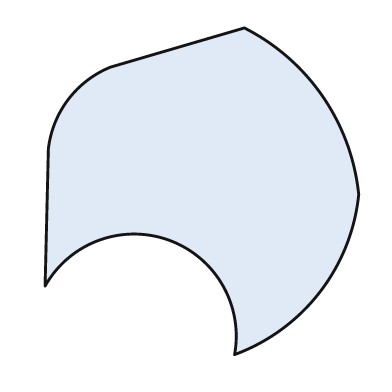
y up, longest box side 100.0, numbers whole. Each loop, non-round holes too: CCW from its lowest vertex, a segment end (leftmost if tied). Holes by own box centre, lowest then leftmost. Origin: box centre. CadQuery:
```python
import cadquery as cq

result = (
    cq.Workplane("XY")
    .moveTo(10.0, -50.0)
    .threePointArc((36.0, -31.0), (48.0, -1.0))
    .threePointArc((37.0, 29.0), (13.0, 50.0))
    .lineTo(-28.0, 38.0)
    .threePointArc((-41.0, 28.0), (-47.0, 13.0))
    .lineTo(-48.0, -29.0)
    .threePointArc((-10.0, -15.0), (10.0, -50.0))
    .close()
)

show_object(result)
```